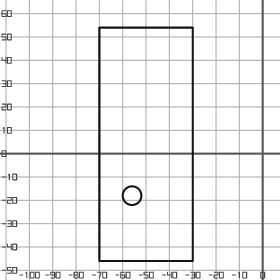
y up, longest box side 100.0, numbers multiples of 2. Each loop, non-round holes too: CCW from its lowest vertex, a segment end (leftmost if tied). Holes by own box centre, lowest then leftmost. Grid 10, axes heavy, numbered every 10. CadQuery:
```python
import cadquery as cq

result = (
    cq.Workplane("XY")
    .moveTo(-70.0, -46.0)
    .lineTo(-30.0, -46.0)
    .lineTo(-30.0, 54.0)
    .lineTo(-70.0, 54.0)
    .close()
    .moveTo(-56.0, -18.0)
    .circle(4.0)
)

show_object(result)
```